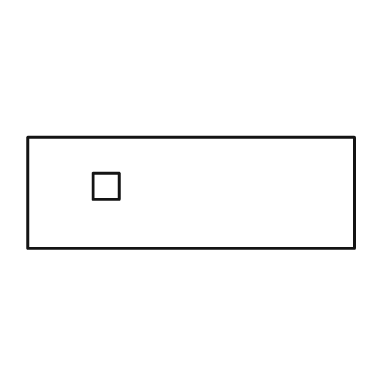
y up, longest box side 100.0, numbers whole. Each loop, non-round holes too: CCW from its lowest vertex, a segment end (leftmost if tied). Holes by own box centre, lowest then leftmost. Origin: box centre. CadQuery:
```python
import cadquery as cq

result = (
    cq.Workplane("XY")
    .moveTo(-50.0, -17.0)
    .lineTo(50.0, -17.0)
    .lineTo(50.0, 17.0)
    .lineTo(-50.0, 17.0)
    .close()
    .moveTo(-30.0, -2.0)
    .lineTo(-22.0, -2.0)
    .lineTo(-22.0, 6.0)
    .lineTo(-30.0, 6.0)
    .close()
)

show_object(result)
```